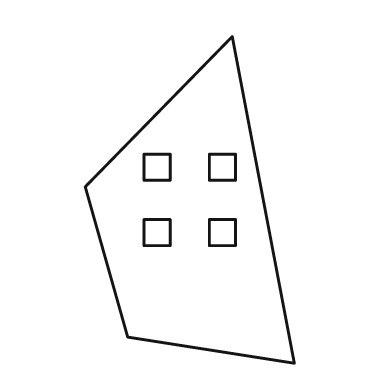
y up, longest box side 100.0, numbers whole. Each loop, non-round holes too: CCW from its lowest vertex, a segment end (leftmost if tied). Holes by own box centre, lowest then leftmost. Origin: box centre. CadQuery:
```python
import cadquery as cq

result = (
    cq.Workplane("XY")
    .moveTo(32.0, -50.0)
    .lineTo(13.0, 50.0)
    .lineTo(-32.0, 4.0)
    .lineTo(-19.0, -42.0)
    .close()
    .moveTo(-14.0, -14.0)
    .lineTo(-6.0, -14.0)
    .lineTo(-6.0, -6.0)
    .lineTo(-14.0, -6.0)
    .close()
    .moveTo(6.0, -14.0)
    .lineTo(14.0, -14.0)
    .lineTo(14.0, -6.0)
    .lineTo(6.0, -6.0)
    .close()
    .moveTo(-14.0, 6.0)
    .lineTo(-6.0, 6.0)
    .lineTo(-6.0, 14.0)
    .lineTo(-14.0, 14.0)
    .close()
    .moveTo(6.0, 6.0)
    .lineTo(14.0, 6.0)
    .lineTo(14.0, 14.0)
    .lineTo(6.0, 14.0)
    .close()
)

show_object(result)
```